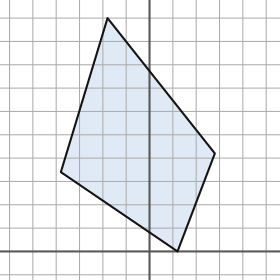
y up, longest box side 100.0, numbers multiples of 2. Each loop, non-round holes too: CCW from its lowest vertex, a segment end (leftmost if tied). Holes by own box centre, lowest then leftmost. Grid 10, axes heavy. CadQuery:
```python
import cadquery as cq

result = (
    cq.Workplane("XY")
    .moveTo(12.0, 0.0)
    .lineTo(28.0, 42.0)
    .lineTo(-18.0, 100.0)
    .lineTo(-38.0, 34.0)
    .close()
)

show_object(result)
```